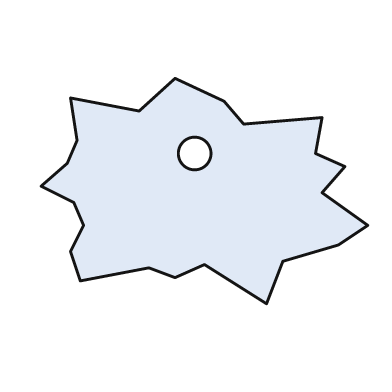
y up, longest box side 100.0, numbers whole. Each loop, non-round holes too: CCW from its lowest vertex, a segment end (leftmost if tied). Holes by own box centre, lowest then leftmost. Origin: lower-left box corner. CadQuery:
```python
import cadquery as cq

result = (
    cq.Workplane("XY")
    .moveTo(69.0, 0.0)
    .lineTo(74.0, 13.0)
    .lineTo(91.0, 18.0)
    .lineTo(100.0, 24.0)
    .lineTo(86.0, 34.0)
    .lineTo(93.0, 42.0)
    .lineTo(84.0, 46.0)
    .lineTo(86.0, 57.0)
    .lineTo(62.0, 55.0)
    .lineTo(56.0, 62.0)
    .lineTo(41.0, 69.0)
    .lineTo(30.0, 59.0)
    .lineTo(9.0, 63.0)
    .lineTo(11.0, 50.0)
    .lineTo(8.0, 43.0)
    .lineTo(0.0, 36.0)
    .lineTo(10.0, 31.0)
    .lineTo(13.0, 24.0)
    .lineTo(9.0, 16.0)
    .lineTo(12.0, 7.0)
    .lineTo(33.0, 11.0)
    .lineTo(41.0, 8.0)
    .lineTo(50.0, 12.0)
    .close()
    .moveTo(47.0, 46.0)
    .circle(5.0)
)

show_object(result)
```